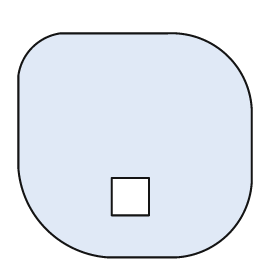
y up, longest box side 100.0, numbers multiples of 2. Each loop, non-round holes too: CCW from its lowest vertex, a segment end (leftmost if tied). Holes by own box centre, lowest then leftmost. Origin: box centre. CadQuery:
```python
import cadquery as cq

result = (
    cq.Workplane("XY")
    .moveTo(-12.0, -48.0)
    .lineTo(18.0, -48.0)
    .threePointArc((40.0, -38.0), (50.0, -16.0))
    .lineTo(50.0, 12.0)
    .threePointArc((40.0, 38.0), (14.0, 48.0))
    .lineTo(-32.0, 48.0)
    .threePointArc((-44.0, 42.0), (-50.0, 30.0))
    .lineTo(-50.0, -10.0)
    .threePointArc((-38.0, -36.0), (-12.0, -48.0))
    .close()
    .moveTo(-10.0, -30.0)
    .lineTo(6.0, -30.0)
    .lineTo(6.0, -14.0)
    .lineTo(-10.0, -14.0)
    .close()
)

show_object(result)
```